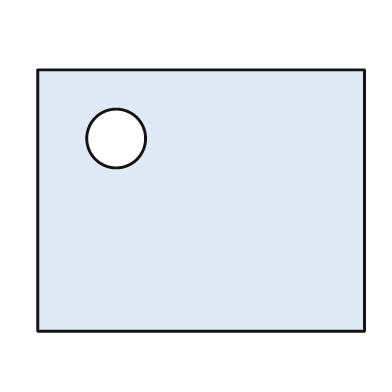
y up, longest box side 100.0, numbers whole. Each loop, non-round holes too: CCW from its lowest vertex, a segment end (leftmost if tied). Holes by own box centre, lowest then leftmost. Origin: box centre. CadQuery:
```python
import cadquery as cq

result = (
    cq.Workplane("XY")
    .moveTo(-50.0, -40.0)
    .lineTo(50.0, -40.0)
    .lineTo(50.0, 40.0)
    .lineTo(-50.0, 40.0)
    .close()
    .moveTo(-26.0, 19.0)
    .circle(9.0)
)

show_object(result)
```